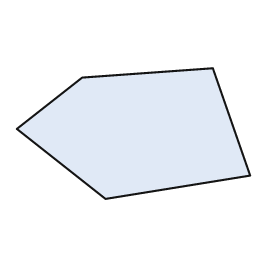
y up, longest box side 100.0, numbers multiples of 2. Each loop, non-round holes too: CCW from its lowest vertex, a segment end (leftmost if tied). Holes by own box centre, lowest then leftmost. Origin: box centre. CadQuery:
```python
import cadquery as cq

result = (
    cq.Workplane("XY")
    .moveTo(-12.0, -28.0)
    .lineTo(50.0, -18.0)
    .lineTo(34.0, 28.0)
    .lineTo(-22.0, 24.0)
    .lineTo(-50.0, 2.0)
    .close()
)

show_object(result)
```